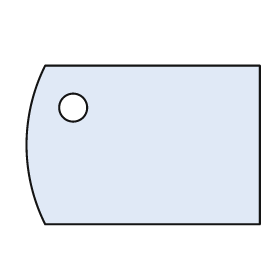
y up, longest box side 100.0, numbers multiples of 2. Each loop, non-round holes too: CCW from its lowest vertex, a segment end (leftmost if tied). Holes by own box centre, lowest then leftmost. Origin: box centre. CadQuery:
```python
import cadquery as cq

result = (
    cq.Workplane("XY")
    .moveTo(-42.0, -34.0)
    .lineTo(50.0, -34.0)
    .lineTo(50.0, 34.0)
    .lineTo(-42.0, 34.0)
    .threePointArc((-50.0, 0.0), (-42.0, -34.0))
    .close()
    .moveTo(-30.0, 16.0)
    .circle(6.0)
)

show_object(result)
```